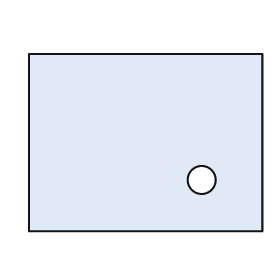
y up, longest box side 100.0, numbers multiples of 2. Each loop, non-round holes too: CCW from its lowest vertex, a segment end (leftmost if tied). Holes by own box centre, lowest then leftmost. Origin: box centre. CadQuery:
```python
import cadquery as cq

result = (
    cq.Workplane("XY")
    .moveTo(-50.0, -38.0)
    .lineTo(50.0, -38.0)
    .lineTo(50.0, 38.0)
    .lineTo(-50.0, 38.0)
    .close()
    .moveTo(24.0, -16.0)
    .circle(6.0)
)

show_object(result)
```